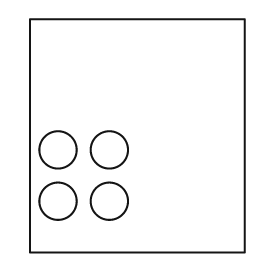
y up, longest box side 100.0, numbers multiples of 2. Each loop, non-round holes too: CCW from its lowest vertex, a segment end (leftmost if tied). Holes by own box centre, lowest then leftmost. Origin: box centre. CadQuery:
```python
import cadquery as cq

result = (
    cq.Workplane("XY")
    .moveTo(-46.0, -50.0)
    .lineTo(46.0, -50.0)
    .lineTo(46.0, 50.0)
    .lineTo(-46.0, 50.0)
    .close()
    .moveTo(-34.0, -28.0)
    .circle(8.0)
    .moveTo(-12.0, -28.0)
    .circle(8.0)
    .moveTo(-34.0, -6.0)
    .circle(8.0)
    .moveTo(-12.0, -6.0)
    .circle(8.0)
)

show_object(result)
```